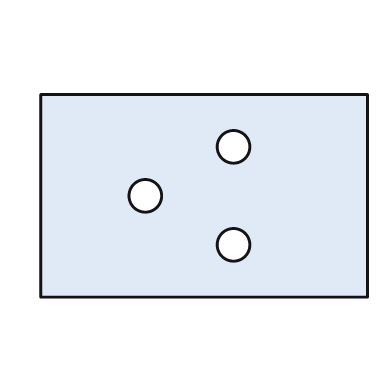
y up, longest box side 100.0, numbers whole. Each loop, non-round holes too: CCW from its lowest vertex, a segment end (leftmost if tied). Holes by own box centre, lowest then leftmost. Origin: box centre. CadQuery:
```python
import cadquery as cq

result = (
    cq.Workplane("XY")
    .moveTo(-50.0, -31.0)
    .lineTo(50.0, -31.0)
    .lineTo(50.0, 31.0)
    .lineTo(-50.0, 31.0)
    .close()
    .moveTo(9.0, -15.0)
    .circle(5.0)
    .moveTo(-18.0, 0.0)
    .circle(5.0)
    .moveTo(9.0, 15.0)
    .circle(5.0)
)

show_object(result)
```